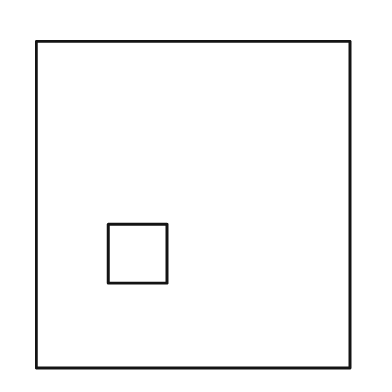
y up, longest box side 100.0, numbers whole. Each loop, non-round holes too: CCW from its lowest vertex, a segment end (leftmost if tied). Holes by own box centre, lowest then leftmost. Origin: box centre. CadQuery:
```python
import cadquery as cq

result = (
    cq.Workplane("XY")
    .moveTo(-48.0, -50.0)
    .lineTo(48.0, -50.0)
    .lineTo(48.0, 50.0)
    .lineTo(-48.0, 50.0)
    .close()
    .moveTo(-26.0, -24.0)
    .lineTo(-8.0, -24.0)
    .lineTo(-8.0, -6.0)
    .lineTo(-26.0, -6.0)
    .close()
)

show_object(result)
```